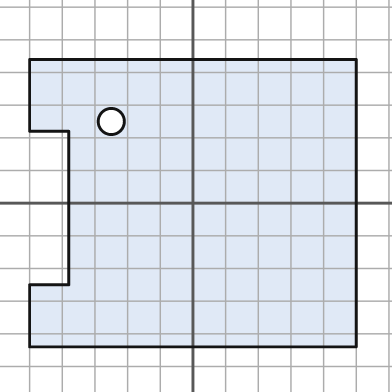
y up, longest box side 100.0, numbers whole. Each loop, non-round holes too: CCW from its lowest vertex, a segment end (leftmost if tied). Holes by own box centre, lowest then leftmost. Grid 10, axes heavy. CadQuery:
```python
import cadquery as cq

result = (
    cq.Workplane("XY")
    .moveTo(-50.0, -44.0)
    .lineTo(50.0, -44.0)
    .lineTo(50.0, 44.0)
    .lineTo(-50.0, 44.0)
    .lineTo(-50.0, 22.0)
    .lineTo(-38.0, 22.0)
    .lineTo(-38.0, -25.0)
    .lineTo(-50.0, -25.0)
    .close()
    .moveTo(-25.0, 25.0)
    .circle(4.0)
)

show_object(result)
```